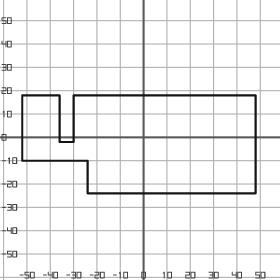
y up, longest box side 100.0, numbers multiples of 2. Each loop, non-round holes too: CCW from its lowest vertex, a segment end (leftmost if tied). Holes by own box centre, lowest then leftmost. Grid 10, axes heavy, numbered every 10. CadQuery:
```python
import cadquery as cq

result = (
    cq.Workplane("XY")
    .moveTo(-24.0, -24.0)
    .lineTo(48.0, -24.0)
    .lineTo(48.0, 18.0)
    .lineTo(-30.0, 18.0)
    .lineTo(-30.0, -2.0)
    .lineTo(-36.0, -2.0)
    .lineTo(-36.0, 18.0)
    .lineTo(-52.0, 18.0)
    .lineTo(-52.0, -10.0)
    .lineTo(-24.0, -10.0)
    .close()
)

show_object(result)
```